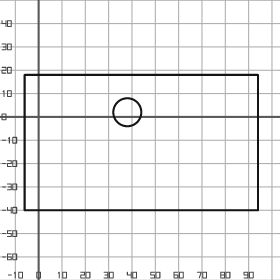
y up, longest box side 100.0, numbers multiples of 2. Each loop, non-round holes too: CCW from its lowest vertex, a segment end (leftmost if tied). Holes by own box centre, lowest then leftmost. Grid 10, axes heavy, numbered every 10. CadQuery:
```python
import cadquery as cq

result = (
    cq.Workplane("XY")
    .moveTo(-6.0, -40.0)
    .lineTo(94.0, -40.0)
    .lineTo(94.0, 18.0)
    .lineTo(-6.0, 18.0)
    .close()
    .moveTo(38.0, 2.0)
    .circle(6.0)
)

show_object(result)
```